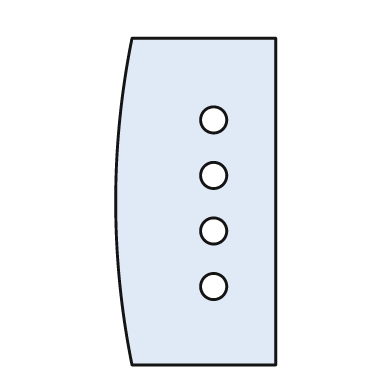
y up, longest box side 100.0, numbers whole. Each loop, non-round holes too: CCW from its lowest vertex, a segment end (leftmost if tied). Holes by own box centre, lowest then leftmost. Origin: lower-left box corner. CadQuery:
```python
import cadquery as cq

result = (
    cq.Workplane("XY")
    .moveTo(5.0, 0.0)
    .lineTo(49.0, 0.0)
    .lineTo(49.0, 100.0)
    .lineTo(5.0, 100.0)
    .threePointArc((0.0, 50.0), (5.0, 0.0))
    .close()
    .moveTo(30.0, 24.0)
    .circle(4.0)
    .moveTo(30.0, 41.0)
    .circle(4.0)
    .moveTo(30.0, 58.0)
    .circle(4.0)
    .moveTo(30.0, 75.0)
    .circle(4.0)
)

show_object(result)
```